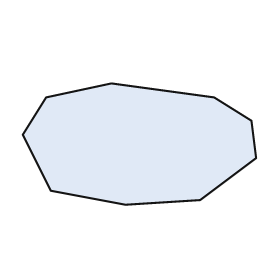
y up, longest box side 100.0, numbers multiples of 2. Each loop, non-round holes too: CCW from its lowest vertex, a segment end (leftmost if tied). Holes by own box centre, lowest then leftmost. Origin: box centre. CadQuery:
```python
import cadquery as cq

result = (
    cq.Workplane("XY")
    .moveTo(-6.0, -26.0)
    .lineTo(26.0, -24.0)
    .lineTo(50.0, -6.0)
    .lineTo(48.0, 10.0)
    .lineTo(32.0, 20.0)
    .lineTo(-12.0, 26.0)
    .lineTo(-40.0, 20.0)
    .lineTo(-50.0, 4.0)
    .lineTo(-38.0, -20.0)
    .close()
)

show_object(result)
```